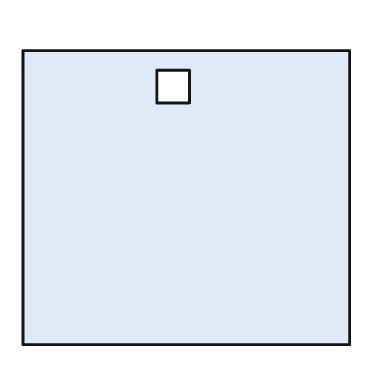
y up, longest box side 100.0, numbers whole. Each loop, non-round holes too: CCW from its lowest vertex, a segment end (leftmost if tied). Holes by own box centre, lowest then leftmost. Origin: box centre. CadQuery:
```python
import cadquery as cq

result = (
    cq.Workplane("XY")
    .moveTo(-50.0, -45.0)
    .lineTo(50.0, -45.0)
    .lineTo(50.0, 45.0)
    .lineTo(-50.0, 45.0)
    .close()
    .moveTo(-9.0, 29.0)
    .lineTo(1.0, 29.0)
    .lineTo(1.0, 39.0)
    .lineTo(-9.0, 39.0)
    .close()
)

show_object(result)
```